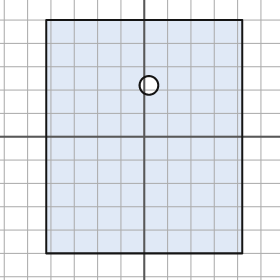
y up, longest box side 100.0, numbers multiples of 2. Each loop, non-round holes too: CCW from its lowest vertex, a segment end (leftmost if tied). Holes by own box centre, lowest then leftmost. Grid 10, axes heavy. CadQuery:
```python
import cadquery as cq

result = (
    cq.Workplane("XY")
    .moveTo(-42.0, -50.0)
    .lineTo(42.0, -50.0)
    .lineTo(42.0, 50.0)
    .lineTo(-42.0, 50.0)
    .close()
    .moveTo(2.0, 22.0)
    .circle(4.0)
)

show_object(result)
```